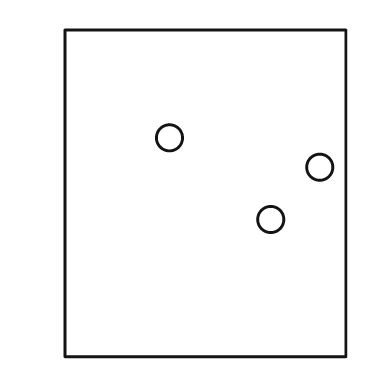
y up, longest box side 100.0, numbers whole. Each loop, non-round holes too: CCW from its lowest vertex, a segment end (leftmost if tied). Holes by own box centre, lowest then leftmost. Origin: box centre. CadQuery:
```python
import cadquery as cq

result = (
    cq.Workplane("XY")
    .moveTo(-43.0, -50.0)
    .lineTo(43.0, -50.0)
    .lineTo(43.0, 50.0)
    .lineTo(-43.0, 50.0)
    .close()
    .moveTo(20.0, -8.0)
    .circle(4.0)
    .moveTo(35.0, 8.0)
    .circle(4.0)
    .moveTo(-11.0, 17.0)
    .circle(4.0)
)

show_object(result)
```